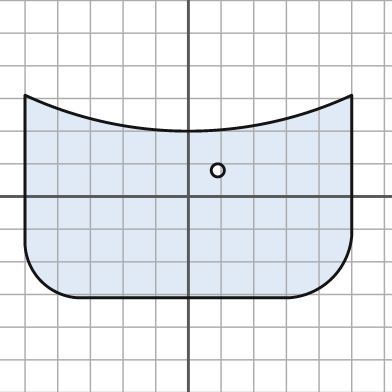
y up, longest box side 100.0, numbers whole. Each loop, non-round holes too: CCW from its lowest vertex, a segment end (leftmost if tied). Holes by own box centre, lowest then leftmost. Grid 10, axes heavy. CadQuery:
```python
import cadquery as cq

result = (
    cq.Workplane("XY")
    .moveTo(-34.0, -31.0)
    .lineTo(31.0, -31.0)
    .threePointArc((44.0, -25.0), (50.0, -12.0))
    .lineTo(50.0, 31.0)
    .threePointArc((0.0, 20.0), (-50.0, 31.0))
    .lineTo(-50.0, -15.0)
    .threePointArc((-45.0, -26.0), (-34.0, -31.0))
    .close()
    .moveTo(9.0, 8.0)
    .circle(2.0)
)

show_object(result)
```